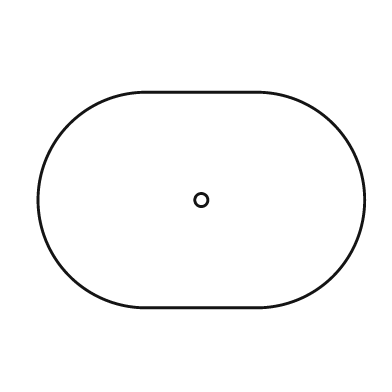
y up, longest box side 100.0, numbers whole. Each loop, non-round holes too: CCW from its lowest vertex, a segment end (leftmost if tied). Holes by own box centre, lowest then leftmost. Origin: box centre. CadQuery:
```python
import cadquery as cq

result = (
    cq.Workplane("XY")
    .moveTo(-17.0, -33.0)
    .lineTo(17.0, -33.0)
    .threePointArc((50.0, 0.0), (17.0, 33.0))
    .lineTo(-17.0, 33.0)
    .threePointArc((-50.0, 0.0), (-17.0, -33.0))
    .close()
    .moveTo(0.0, 0.0)
    .circle(2.0)
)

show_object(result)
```